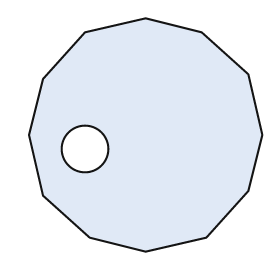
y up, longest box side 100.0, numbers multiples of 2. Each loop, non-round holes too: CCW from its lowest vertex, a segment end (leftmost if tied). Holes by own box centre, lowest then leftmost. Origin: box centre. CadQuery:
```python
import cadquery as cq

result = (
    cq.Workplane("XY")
    .moveTo(0.0, -50.0)
    .lineTo(26.0, -44.0)
    .lineTo(44.0, -24.0)
    .lineTo(50.0, 0.0)
    .lineTo(44.0, 26.0)
    .lineTo(24.0, 44.0)
    .lineTo(0.0, 50.0)
    .lineTo(-26.0, 44.0)
    .lineTo(-44.0, 24.0)
    .lineTo(-50.0, 0.0)
    .lineTo(-44.0, -26.0)
    .lineTo(-24.0, -44.0)
    .close()
    .moveTo(-26.0, -6.0)
    .circle(10.0)
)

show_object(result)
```